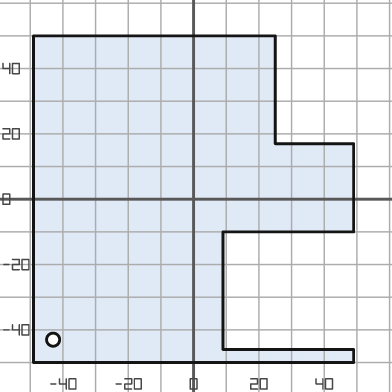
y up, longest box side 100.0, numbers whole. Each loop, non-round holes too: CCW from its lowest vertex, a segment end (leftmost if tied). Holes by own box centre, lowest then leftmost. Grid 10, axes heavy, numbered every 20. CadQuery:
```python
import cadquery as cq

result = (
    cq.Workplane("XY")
    .moveTo(-49.0, -50.0)
    .lineTo(49.0, -50.0)
    .lineTo(49.0, -46.0)
    .lineTo(9.0, -46.0)
    .lineTo(9.0, -10.0)
    .lineTo(49.0, -10.0)
    .lineTo(49.0, 17.0)
    .lineTo(25.0, 17.0)
    .lineTo(25.0, 50.0)
    .lineTo(-49.0, 50.0)
    .close()
    .moveTo(-43.0, -43.0)
    .circle(2.0)
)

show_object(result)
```